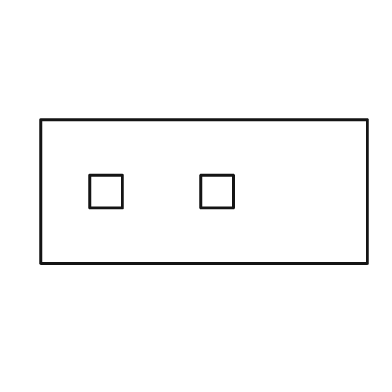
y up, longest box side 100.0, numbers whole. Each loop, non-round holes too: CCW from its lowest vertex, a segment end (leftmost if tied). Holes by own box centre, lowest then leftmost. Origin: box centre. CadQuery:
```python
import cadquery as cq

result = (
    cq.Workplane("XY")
    .moveTo(-50.0, -22.0)
    .lineTo(50.0, -22.0)
    .lineTo(50.0, 22.0)
    .lineTo(-50.0, 22.0)
    .close()
    .moveTo(-35.0, -5.0)
    .lineTo(-25.0, -5.0)
    .lineTo(-25.0, 5.0)
    .lineTo(-35.0, 5.0)
    .close()
    .moveTo(-1.0, -5.0)
    .lineTo(9.0, -5.0)
    .lineTo(9.0, 5.0)
    .lineTo(-1.0, 5.0)
    .close()
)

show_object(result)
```